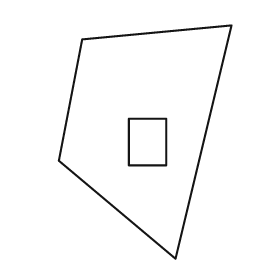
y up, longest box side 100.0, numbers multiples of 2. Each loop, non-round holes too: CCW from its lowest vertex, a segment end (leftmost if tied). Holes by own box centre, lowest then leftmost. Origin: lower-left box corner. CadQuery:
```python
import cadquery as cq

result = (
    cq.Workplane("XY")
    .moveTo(50.0, 0.0)
    .lineTo(74.0, 100.0)
    .lineTo(10.0, 94.0)
    .lineTo(0.0, 42.0)
    .close()
    .moveTo(30.0, 40.0)
    .lineTo(46.0, 40.0)
    .lineTo(46.0, 60.0)
    .lineTo(30.0, 60.0)
    .close()
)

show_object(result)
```